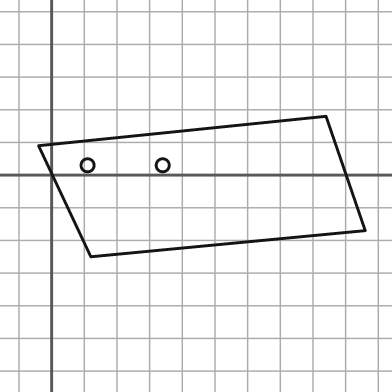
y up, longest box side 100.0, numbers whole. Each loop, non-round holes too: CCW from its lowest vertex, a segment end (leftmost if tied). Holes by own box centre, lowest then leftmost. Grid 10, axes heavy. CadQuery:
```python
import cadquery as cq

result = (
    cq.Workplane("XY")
    .moveTo(12.0, -25.0)
    .lineTo(96.0, -17.0)
    .lineTo(84.0, 18.0)
    .lineTo(-4.0, 9.0)
    .close()
    .moveTo(11.0, 3.0)
    .circle(2.0)
    .moveTo(34.0, 3.0)
    .circle(2.0)
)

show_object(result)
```